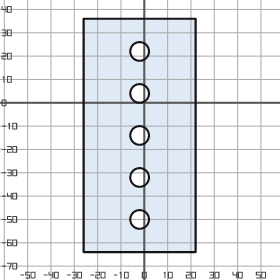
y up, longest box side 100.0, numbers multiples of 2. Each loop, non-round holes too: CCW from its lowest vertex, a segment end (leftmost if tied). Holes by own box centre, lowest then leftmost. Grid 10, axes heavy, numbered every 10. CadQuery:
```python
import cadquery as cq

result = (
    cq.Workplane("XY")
    .moveTo(-26.0, -64.0)
    .lineTo(22.0, -64.0)
    .lineTo(22.0, 36.0)
    .lineTo(-26.0, 36.0)
    .close()
    .moveTo(-2.0, -50.0)
    .circle(4.0)
    .moveTo(-2.0, -32.0)
    .circle(4.0)
    .moveTo(-2.0, -14.0)
    .circle(4.0)
    .moveTo(-2.0, 4.0)
    .circle(4.0)
    .moveTo(-2.0, 22.0)
    .circle(4.0)
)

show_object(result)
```